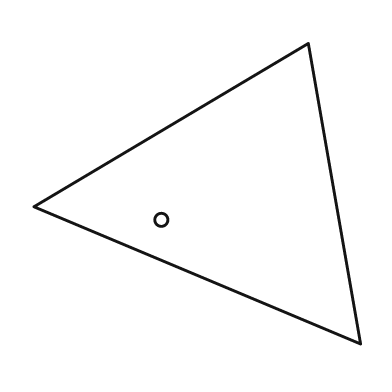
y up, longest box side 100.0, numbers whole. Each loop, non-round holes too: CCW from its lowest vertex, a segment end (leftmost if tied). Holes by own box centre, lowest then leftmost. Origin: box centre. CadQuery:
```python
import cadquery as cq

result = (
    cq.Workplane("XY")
    .moveTo(50.0, -46.0)
    .lineTo(34.0, 46.0)
    .lineTo(-50.0, -4.0)
    .close()
    .moveTo(-11.0, -8.0)
    .circle(2.0)
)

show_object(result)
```